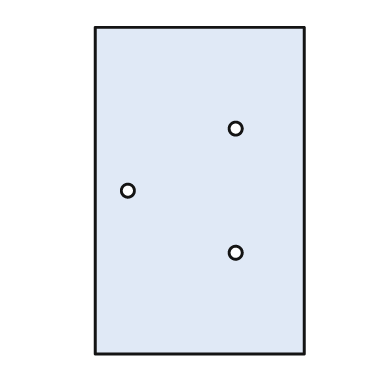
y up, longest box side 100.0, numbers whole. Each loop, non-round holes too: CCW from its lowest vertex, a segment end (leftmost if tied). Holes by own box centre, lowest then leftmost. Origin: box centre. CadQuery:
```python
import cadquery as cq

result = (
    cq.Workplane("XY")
    .moveTo(-32.0, -50.0)
    .lineTo(32.0, -50.0)
    .lineTo(32.0, 50.0)
    .lineTo(-32.0, 50.0)
    .close()
    .moveTo(11.0, -19.0)
    .circle(2.0)
    .moveTo(-22.0, 0.0)
    .circle(2.0)
    .moveTo(11.0, 19.0)
    .circle(2.0)
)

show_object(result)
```